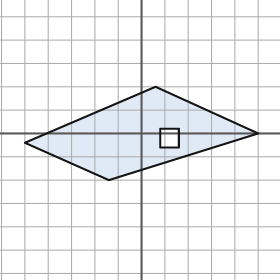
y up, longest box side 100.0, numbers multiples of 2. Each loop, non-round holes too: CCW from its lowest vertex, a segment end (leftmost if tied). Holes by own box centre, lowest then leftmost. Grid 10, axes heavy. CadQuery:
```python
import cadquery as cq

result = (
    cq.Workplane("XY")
    .moveTo(-14.0, -20.0)
    .lineTo(50.0, 0.0)
    .lineTo(6.0, 20.0)
    .lineTo(-50.0, -4.0)
    .close()
    .moveTo(8.0, -6.0)
    .lineTo(16.0, -6.0)
    .lineTo(16.0, 2.0)
    .lineTo(8.0, 2.0)
    .close()
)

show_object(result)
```